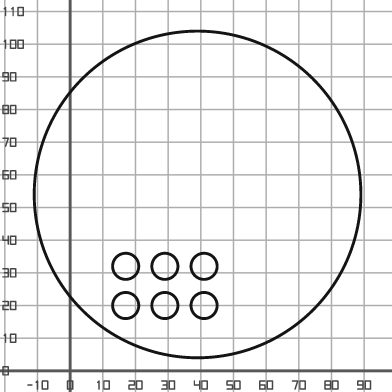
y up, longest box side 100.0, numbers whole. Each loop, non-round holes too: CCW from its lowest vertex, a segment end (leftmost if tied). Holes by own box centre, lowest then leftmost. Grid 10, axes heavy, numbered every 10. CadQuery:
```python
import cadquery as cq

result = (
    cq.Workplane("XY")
    .moveTo(39.0, 54.0)
    .circle(50.0)
    .moveTo(17.0, 20.0)
    .circle(4.0)
    .moveTo(29.0, 20.0)
    .circle(4.0)
    .moveTo(41.0, 20.0)
    .circle(4.0)
    .moveTo(17.0, 32.0)
    .circle(4.0)
    .moveTo(29.0, 32.0)
    .circle(4.0)
    .moveTo(41.0, 32.0)
    .circle(4.0)
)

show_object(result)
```